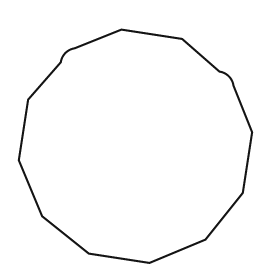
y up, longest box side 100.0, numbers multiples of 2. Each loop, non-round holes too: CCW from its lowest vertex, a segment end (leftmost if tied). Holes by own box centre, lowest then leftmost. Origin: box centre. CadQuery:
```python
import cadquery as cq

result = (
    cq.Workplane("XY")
    .moveTo(6.0, -50.0)
    .lineTo(30.0, -40.0)
    .lineTo(46.0, -20.0)
    .lineTo(50.0, 6.0)
    .lineTo(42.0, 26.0)
    .threePointArc((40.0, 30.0), (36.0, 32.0))
    .lineTo(20.0, 46.0)
    .lineTo(-6.0, 50.0)
    .lineTo(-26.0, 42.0)
    .threePointArc((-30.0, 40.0), (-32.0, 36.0))
    .lineTo(-46.0, 20.0)
    .lineTo(-50.0, -6.0)
    .lineTo(-40.0, -30.0)
    .lineTo(-20.0, -46.0)
    .close()
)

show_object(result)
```